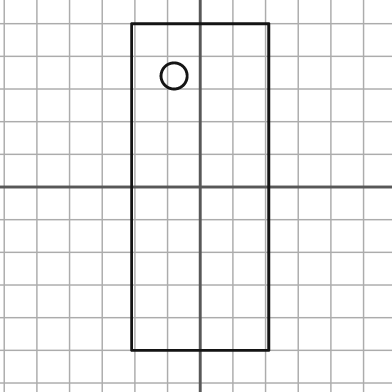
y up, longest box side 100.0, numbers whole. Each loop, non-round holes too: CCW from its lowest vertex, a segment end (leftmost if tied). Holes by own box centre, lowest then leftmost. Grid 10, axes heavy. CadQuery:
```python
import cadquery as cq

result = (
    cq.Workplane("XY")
    .moveTo(-21.0, -50.0)
    .lineTo(21.0, -50.0)
    .lineTo(21.0, 50.0)
    .lineTo(-21.0, 50.0)
    .close()
    .moveTo(-8.0, 34.0)
    .circle(4.0)
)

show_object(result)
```